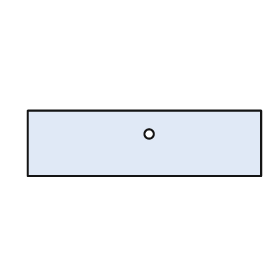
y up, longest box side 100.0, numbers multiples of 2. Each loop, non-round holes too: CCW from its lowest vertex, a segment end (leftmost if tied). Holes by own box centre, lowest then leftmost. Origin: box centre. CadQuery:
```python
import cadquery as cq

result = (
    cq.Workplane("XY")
    .moveTo(-50.0, -14.0)
    .lineTo(50.0, -14.0)
    .lineTo(50.0, 14.0)
    .lineTo(-50.0, 14.0)
    .close()
    .moveTo(2.0, 4.0)
    .circle(2.0)
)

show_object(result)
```